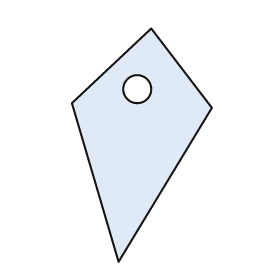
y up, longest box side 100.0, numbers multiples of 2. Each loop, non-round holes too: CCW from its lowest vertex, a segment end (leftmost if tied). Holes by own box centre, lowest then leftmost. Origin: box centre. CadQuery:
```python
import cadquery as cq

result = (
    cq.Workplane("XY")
    .moveTo(-10.0, -50.0)
    .lineTo(30.0, 16.0)
    .lineTo(4.0, 50.0)
    .lineTo(-30.0, 18.0)
    .close()
    .moveTo(-2.0, 24.0)
    .circle(6.0)
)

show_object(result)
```